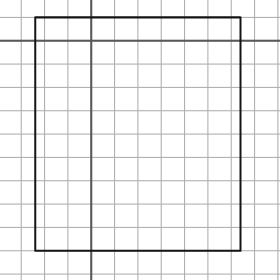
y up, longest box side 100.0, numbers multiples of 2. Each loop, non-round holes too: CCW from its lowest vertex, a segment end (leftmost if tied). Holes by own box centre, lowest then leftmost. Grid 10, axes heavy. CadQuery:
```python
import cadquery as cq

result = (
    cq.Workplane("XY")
    .moveTo(-24.0, -90.0)
    .lineTo(64.0, -90.0)
    .lineTo(64.0, 10.0)
    .lineTo(-24.0, 10.0)
    .close()
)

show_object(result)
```